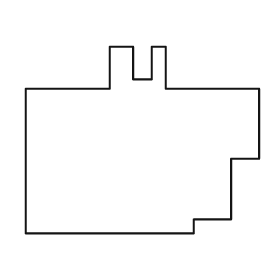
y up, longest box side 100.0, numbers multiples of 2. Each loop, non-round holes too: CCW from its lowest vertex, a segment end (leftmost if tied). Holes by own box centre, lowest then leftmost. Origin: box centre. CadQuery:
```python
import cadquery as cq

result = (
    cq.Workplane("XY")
    .moveTo(-50.0, -40.0)
    .lineTo(22.0, -40.0)
    .lineTo(22.0, -34.0)
    .lineTo(38.0, -34.0)
    .lineTo(38.0, -8.0)
    .lineTo(50.0, -8.0)
    .lineTo(50.0, 22.0)
    .lineTo(10.0, 22.0)
    .lineTo(10.0, 40.0)
    .lineTo(4.0, 40.0)
    .lineTo(4.0, 26.0)
    .lineTo(-4.0, 26.0)
    .lineTo(-4.0, 40.0)
    .lineTo(-14.0, 40.0)
    .lineTo(-14.0, 22.0)
    .lineTo(-50.0, 22.0)
    .close()
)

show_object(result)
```